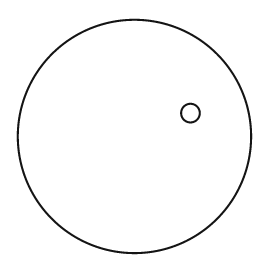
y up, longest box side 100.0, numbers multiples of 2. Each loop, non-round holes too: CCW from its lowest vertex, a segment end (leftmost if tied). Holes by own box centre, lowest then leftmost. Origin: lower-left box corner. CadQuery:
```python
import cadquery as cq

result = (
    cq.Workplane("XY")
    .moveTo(50.0, 50.0)
    .circle(50.0)
    .moveTo(74.0, 60.0)
    .circle(4.0)
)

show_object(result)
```